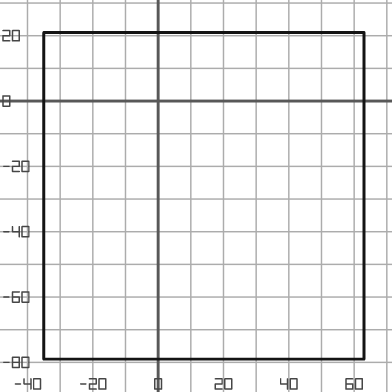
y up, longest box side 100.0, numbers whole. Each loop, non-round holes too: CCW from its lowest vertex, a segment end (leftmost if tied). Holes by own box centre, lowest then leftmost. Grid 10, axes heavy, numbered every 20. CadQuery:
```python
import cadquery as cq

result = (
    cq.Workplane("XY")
    .moveTo(-35.0, -79.0)
    .lineTo(63.0, -79.0)
    .lineTo(63.0, 21.0)
    .lineTo(-35.0, 21.0)
    .close()
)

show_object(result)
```